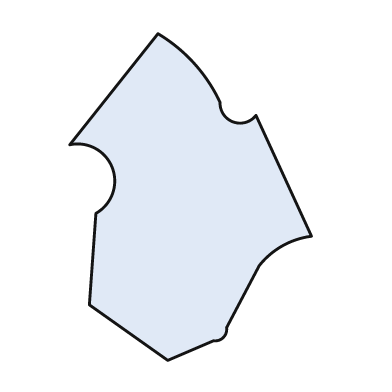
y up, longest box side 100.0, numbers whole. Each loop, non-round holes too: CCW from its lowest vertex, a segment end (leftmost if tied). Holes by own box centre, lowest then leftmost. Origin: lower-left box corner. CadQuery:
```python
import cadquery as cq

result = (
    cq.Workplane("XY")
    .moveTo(30.0, 0.0)
    .lineTo(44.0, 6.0)
    .threePointArc((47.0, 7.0), (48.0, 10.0))
    .lineTo(58.0, 29.0)
    .threePointArc((65.0, 35.0), (74.0, 38.0))
    .lineTo(57.0, 75.0)
    .threePointArc((50.0, 73.0), (46.0, 79.0))
    .threePointArc((38.0, 91.0), (27.0, 100.0))
    .lineTo(0.0, 66.0)
    .threePointArc((13.0, 59.0), (8.0, 45.0))
    .lineTo(6.0, 17.0)
    .close()
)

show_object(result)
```